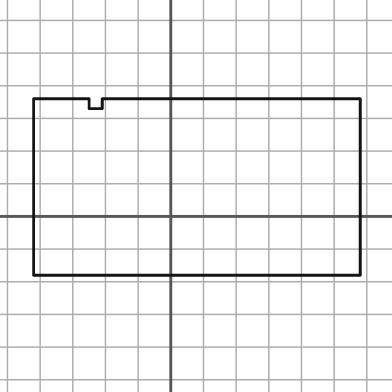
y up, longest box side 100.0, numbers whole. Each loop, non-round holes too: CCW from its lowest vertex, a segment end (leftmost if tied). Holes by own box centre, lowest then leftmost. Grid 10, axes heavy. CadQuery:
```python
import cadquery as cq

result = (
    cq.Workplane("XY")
    .moveTo(-42.0, -18.0)
    .lineTo(58.0, -18.0)
    .lineTo(58.0, 36.0)
    .lineTo(-21.0, 36.0)
    .lineTo(-21.0, 33.0)
    .lineTo(-25.0, 33.0)
    .lineTo(-25.0, 36.0)
    .lineTo(-42.0, 36.0)
    .close()
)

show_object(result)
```